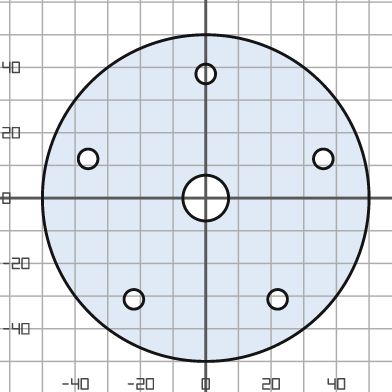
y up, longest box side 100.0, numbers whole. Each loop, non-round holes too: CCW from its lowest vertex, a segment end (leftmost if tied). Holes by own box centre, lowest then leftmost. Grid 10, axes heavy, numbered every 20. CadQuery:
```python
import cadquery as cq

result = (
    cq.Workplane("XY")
    .moveTo(0.0, 0.0)
    .circle(50.0)
    .moveTo(-22.0, -31.0)
    .circle(3.0)
    .moveTo(22.0, -31.0)
    .circle(3.0)
    .moveTo(0.0, 0.0)
    .circle(7.0)
    .moveTo(-36.0, 12.0)
    .circle(3.0)
    .moveTo(36.0, 12.0)
    .circle(3.0)
    .moveTo(0.0, 38.0)
    .circle(3.0)
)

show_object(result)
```